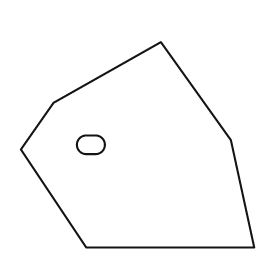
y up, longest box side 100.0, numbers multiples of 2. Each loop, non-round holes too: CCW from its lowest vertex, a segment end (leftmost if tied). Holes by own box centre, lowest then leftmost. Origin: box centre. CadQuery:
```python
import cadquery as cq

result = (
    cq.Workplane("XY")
    .moveTo(-22.0, -44.0)
    .lineTo(50.0, -44.0)
    .lineTo(40.0, 2.0)
    .lineTo(10.0, 44.0)
    .lineTo(-36.0, 18.0)
    .lineTo(-50.0, -2.0)
    .close()
    .moveTo(-22.0, -4.0)
    .lineTo(-18.0, -4.0)
    .threePointArc((-14.0, 0.0), (-18.0, 4.0))
    .lineTo(-22.0, 4.0)
    .threePointArc((-26.0, 0.0), (-22.0, -4.0))
    .close()
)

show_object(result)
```